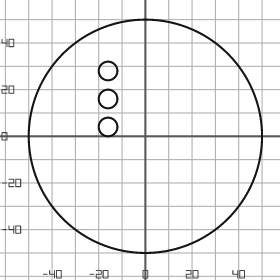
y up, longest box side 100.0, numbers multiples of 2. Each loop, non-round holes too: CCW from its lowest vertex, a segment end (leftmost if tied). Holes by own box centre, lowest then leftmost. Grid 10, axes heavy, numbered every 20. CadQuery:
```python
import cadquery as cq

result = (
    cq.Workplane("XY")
    .moveTo(0.0, 0.0)
    .circle(50.0)
    .moveTo(-16.0, 4.0)
    .circle(4.0)
    .moveTo(-16.0, 16.0)
    .circle(4.0)
    .moveTo(-16.0, 28.0)
    .circle(4.0)
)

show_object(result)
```